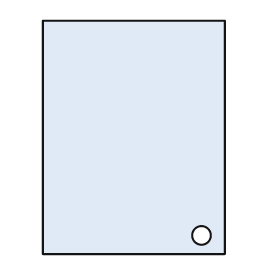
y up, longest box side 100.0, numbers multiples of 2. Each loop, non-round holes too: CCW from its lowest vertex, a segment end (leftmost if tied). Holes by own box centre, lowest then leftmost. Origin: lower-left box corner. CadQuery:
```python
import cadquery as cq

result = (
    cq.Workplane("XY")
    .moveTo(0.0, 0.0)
    .lineTo(78.0, 0.0)
    .lineTo(78.0, 100.0)
    .lineTo(0.0, 100.0)
    .close()
    .moveTo(68.0, 8.0)
    .circle(4.0)
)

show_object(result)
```